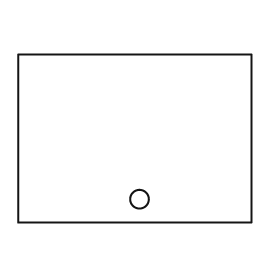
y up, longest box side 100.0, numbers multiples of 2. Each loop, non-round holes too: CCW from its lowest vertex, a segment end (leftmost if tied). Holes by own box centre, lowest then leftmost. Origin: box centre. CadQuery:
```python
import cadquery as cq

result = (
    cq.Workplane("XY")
    .moveTo(-50.0, -36.0)
    .lineTo(50.0, -36.0)
    .lineTo(50.0, 36.0)
    .lineTo(-50.0, 36.0)
    .close()
    .moveTo(2.0, -26.0)
    .circle(4.0)
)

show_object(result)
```